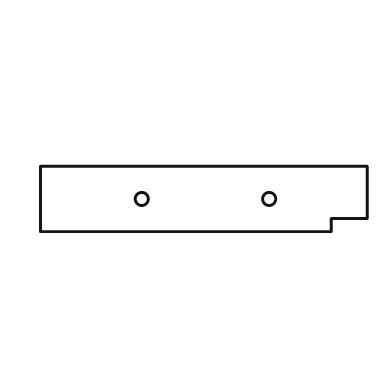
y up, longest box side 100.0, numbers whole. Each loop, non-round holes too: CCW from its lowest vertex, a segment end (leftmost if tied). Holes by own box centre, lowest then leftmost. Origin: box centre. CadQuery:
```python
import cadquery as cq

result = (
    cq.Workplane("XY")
    .moveTo(-50.0, -10.0)
    .lineTo(39.0, -10.0)
    .lineTo(39.0, -6.0)
    .lineTo(50.0, -6.0)
    .lineTo(50.0, 10.0)
    .lineTo(-50.0, 10.0)
    .close()
    .moveTo(-19.0, 0.0)
    .circle(2.0)
    .moveTo(20.0, 0.0)
    .circle(2.0)
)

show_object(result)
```